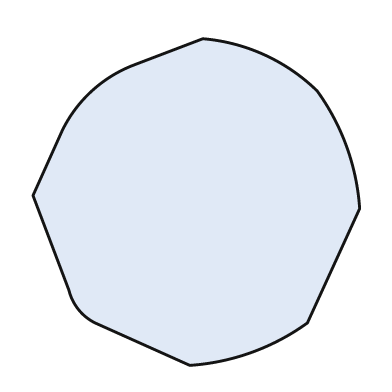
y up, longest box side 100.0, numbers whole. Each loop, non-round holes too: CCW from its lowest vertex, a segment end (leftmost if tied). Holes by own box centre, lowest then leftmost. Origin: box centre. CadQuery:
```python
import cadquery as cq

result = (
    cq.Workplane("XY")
    .moveTo(-2.0, -50.0)
    .threePointArc((17.0, -46.0), (34.0, -37.0))
    .lineTo(50.0, -2.0)
    .threePointArc((46.0, 17.0), (37.0, 34.0))
    .threePointArc((21.0, 45.0), (2.0, 50.0))
    .lineTo(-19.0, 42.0)
    .threePointArc((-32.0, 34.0), (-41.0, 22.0))
    .lineTo(-50.0, 2.0)
    .lineTo(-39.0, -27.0)
    .threePointArc((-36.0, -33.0), (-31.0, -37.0))
    .close()
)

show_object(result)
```